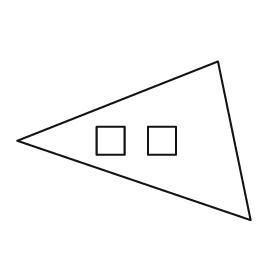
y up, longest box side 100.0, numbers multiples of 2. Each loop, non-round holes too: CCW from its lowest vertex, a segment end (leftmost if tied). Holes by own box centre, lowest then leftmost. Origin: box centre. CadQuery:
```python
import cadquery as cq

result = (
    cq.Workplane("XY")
    .moveTo(50.0, -34.0)
    .lineTo(36.0, 34.0)
    .lineTo(-50.0, 0.0)
    .close()
    .moveTo(-16.0, -6.0)
    .lineTo(-4.0, -6.0)
    .lineTo(-4.0, 6.0)
    .lineTo(-16.0, 6.0)
    .close()
    .moveTo(6.0, -6.0)
    .lineTo(18.0, -6.0)
    .lineTo(18.0, 6.0)
    .lineTo(6.0, 6.0)
    .close()
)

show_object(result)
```